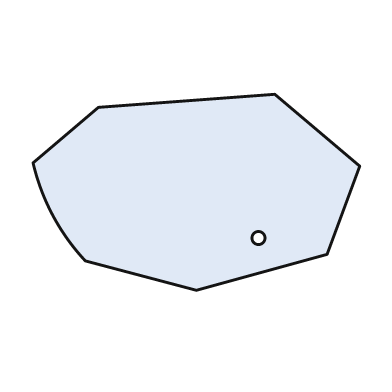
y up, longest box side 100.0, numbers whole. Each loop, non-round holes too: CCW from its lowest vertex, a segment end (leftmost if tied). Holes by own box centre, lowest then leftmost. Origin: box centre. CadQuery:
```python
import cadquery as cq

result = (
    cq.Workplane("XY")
    .moveTo(0.0, -30.0)
    .lineTo(40.0, -19.0)
    .lineTo(50.0, 8.0)
    .lineTo(24.0, 30.0)
    .lineTo(-30.0, 26.0)
    .lineTo(-50.0, 9.0)
    .threePointArc((-44.0, -7.0), (-34.0, -21.0))
    .close()
    .moveTo(19.0, -14.0)
    .circle(2.0)
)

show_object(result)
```